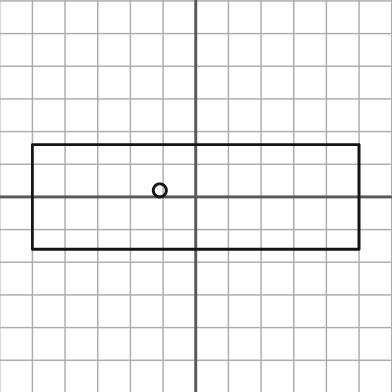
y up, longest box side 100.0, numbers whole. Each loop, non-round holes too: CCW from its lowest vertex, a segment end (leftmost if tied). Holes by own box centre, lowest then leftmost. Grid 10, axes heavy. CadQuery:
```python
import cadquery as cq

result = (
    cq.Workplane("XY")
    .moveTo(-50.0, -16.0)
    .lineTo(50.0, -16.0)
    .lineTo(50.0, 16.0)
    .lineTo(-50.0, 16.0)
    .close()
    .moveTo(-11.0, 2.0)
    .circle(2.0)
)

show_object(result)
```